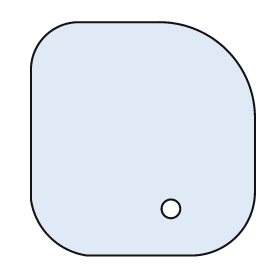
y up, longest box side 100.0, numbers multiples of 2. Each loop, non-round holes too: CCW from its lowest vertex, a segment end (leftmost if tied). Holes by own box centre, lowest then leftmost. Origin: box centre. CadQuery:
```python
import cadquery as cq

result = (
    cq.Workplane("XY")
    .moveTo(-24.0, -50.0)
    .lineTo(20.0, -50.0)
    .threePointArc((40.0, -42.0), (48.0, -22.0))
    .lineTo(48.0, 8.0)
    .threePointArc((36.0, 38.0), (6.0, 50.0))
    .lineTo(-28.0, 50.0)
    .threePointArc((-42.0, 44.0), (-48.0, 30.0))
    .lineTo(-48.0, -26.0)
    .threePointArc((-40.0, -42.0), (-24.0, -50.0))
    .close()
    .moveTo(12.0, -30.0)
    .circle(4.0)
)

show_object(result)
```